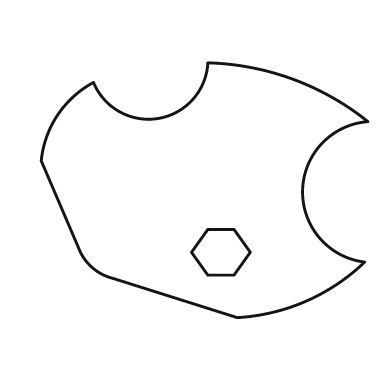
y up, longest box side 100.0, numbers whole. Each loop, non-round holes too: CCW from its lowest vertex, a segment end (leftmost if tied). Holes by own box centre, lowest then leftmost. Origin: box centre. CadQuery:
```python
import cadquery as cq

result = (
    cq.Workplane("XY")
    .moveTo(10.0, -39.0)
    .threePointArc((31.0, -34.0), (49.0, -22.0))
    .threePointArc((30.0, 0.0), (50.0, 21.0))
    .threePointArc((27.0, 34.0), (1.0, 39.0))
    .threePointArc((-14.0, 22.0), (-34.0, 33.0))
    .threePointArc((-45.0, 23.0), (-50.0, 9.0))
    .lineTo(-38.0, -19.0)
    .threePointArc((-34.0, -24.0), (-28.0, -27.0))
    .close()
    .moveTo(1.0, -26.0)
    .lineTo(9.0, -26.0)
    .lineTo(14.0, -19.0)
    .lineTo(9.0, -12.0)
    .lineTo(1.0, -12.0)
    .lineTo(-4.0, -19.0)
    .close()
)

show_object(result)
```